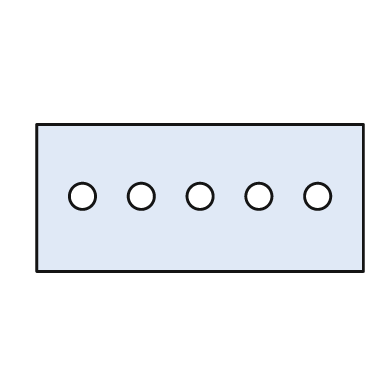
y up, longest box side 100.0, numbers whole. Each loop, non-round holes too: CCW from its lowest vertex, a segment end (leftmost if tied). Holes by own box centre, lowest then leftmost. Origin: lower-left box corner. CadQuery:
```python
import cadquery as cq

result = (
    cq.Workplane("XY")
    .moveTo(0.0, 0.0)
    .lineTo(100.0, 0.0)
    .lineTo(100.0, 45.0)
    .lineTo(0.0, 45.0)
    .close()
    .moveTo(14.0, 23.0)
    .circle(4.0)
    .moveTo(32.0, 23.0)
    .circle(4.0)
    .moveTo(50.0, 23.0)
    .circle(4.0)
    .moveTo(68.0, 23.0)
    .circle(4.0)
    .moveTo(86.0, 23.0)
    .circle(4.0)
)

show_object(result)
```